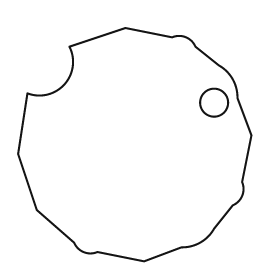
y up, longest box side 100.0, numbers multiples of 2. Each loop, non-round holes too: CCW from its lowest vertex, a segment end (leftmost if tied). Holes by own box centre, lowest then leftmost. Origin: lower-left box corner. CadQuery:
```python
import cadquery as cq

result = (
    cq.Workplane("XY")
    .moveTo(54.0, 0.0)
    .lineTo(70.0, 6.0)
    .threePointArc((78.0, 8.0), (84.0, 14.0))
    .lineTo(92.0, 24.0)
    .threePointArc((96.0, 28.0), (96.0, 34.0))
    .lineTo(100.0, 54.0)
    .lineTo(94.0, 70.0)
    .threePointArc((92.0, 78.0), (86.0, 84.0))
    .lineTo(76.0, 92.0)
    .threePointArc((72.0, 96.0), (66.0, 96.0))
    .lineTo(46.0, 100.0)
    .lineTo(22.0, 92.0)
    .threePointArc((20.0, 76.0), (4.0, 72.0))
    .lineTo(0.0, 46.0)
    .lineTo(8.0, 22.0)
    .lineTo(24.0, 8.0)
    .threePointArc((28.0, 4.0), (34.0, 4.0))
    .close()
    .moveTo(84.0, 68.0)
    .circle(6.0)
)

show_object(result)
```